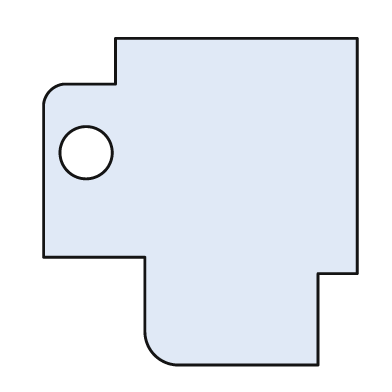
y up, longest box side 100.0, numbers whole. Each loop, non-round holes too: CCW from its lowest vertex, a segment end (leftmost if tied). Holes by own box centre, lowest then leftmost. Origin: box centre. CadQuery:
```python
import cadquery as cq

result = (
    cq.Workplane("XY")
    .moveTo(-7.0, -50.0)
    .lineTo(36.0, -50.0)
    .lineTo(36.0, -22.0)
    .lineTo(48.0, -22.0)
    .lineTo(48.0, 50.0)
    .lineTo(-26.0, 50.0)
    .lineTo(-26.0, 36.0)
    .lineTo(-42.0, 36.0)
    .threePointArc((-46.0, 34.0), (-48.0, 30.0))
    .lineTo(-48.0, -17.0)
    .lineTo(-17.0, -17.0)
    .lineTo(-17.0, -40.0)
    .threePointArc((-14.0, -47.0), (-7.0, -50.0))
    .close()
    .moveTo(-35.0, 15.0)
    .circle(8.0)
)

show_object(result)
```